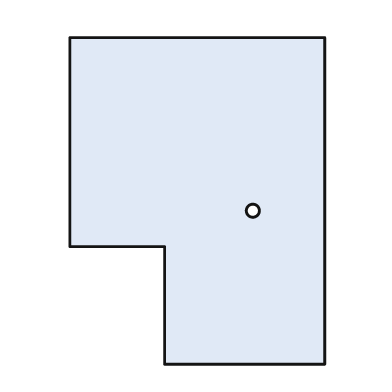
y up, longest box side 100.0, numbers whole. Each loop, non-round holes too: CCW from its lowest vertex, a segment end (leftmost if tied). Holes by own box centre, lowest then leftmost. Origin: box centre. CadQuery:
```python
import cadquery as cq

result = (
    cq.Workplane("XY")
    .moveTo(-10.0, -50.0)
    .lineTo(39.0, -50.0)
    .lineTo(39.0, 50.0)
    .lineTo(-39.0, 50.0)
    .lineTo(-39.0, -14.0)
    .lineTo(-10.0, -14.0)
    .close()
    .moveTo(17.0, -3.0)
    .circle(2.0)
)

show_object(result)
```